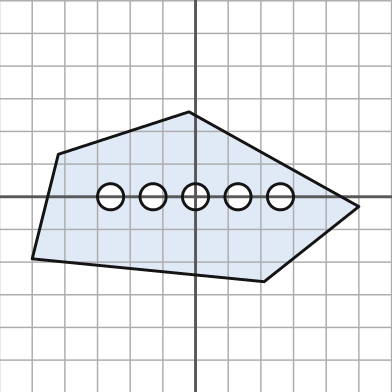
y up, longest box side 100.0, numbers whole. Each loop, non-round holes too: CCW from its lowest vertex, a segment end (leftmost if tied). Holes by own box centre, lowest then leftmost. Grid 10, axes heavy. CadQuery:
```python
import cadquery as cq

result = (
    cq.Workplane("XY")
    .moveTo(21.0, -26.0)
    .lineTo(50.0, -3.0)
    .lineTo(-2.0, 26.0)
    .lineTo(-42.0, 13.0)
    .lineTo(-50.0, -19.0)
    .close()
    .moveTo(-26.0, 0.0)
    .circle(4.0)
    .moveTo(-13.0, 0.0)
    .circle(4.0)
    .moveTo(0.0, 0.0)
    .circle(4.0)
    .moveTo(13.0, 0.0)
    .circle(4.0)
    .moveTo(26.0, 0.0)
    .circle(4.0)
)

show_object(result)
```